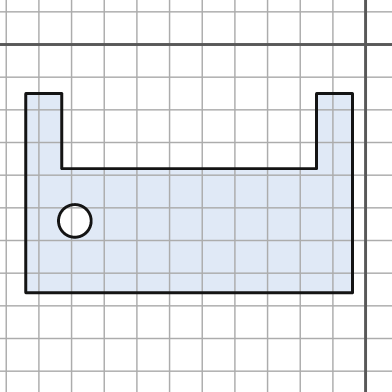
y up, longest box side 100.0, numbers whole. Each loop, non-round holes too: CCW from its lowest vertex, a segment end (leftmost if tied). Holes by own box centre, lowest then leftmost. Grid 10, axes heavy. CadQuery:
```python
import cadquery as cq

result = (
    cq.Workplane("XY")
    .moveTo(-104.0, -76.0)
    .lineTo(-4.0, -76.0)
    .lineTo(-4.0, -15.0)
    .lineTo(-15.0, -15.0)
    .lineTo(-15.0, -38.0)
    .lineTo(-93.0, -38.0)
    .lineTo(-93.0, -15.0)
    .lineTo(-104.0, -15.0)
    .close()
    .moveTo(-89.0, -54.0)
    .circle(5.0)
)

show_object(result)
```